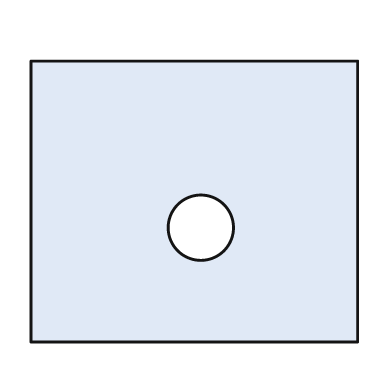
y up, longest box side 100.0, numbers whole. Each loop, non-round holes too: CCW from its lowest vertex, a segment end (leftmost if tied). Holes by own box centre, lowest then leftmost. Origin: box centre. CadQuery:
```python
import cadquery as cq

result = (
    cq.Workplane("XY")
    .moveTo(-50.0, -43.0)
    .lineTo(50.0, -43.0)
    .lineTo(50.0, 43.0)
    .lineTo(-50.0, 43.0)
    .close()
    .moveTo(2.0, -8.0)
    .circle(10.0)
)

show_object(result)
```